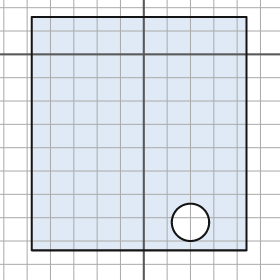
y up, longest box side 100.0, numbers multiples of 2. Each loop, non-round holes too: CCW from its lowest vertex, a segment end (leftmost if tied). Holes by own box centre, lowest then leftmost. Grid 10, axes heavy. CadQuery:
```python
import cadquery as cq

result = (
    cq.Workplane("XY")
    .moveTo(-48.0, -84.0)
    .lineTo(44.0, -84.0)
    .lineTo(44.0, 16.0)
    .lineTo(-48.0, 16.0)
    .close()
    .moveTo(20.0, -72.0)
    .circle(8.0)
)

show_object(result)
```